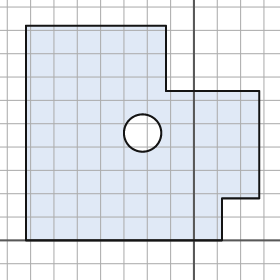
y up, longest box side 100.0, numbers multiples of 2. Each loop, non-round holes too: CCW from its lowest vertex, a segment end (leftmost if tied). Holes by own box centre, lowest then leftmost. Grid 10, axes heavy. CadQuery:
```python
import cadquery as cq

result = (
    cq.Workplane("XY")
    .moveTo(-72.0, 0.0)
    .lineTo(12.0, 0.0)
    .lineTo(12.0, 18.0)
    .lineTo(28.0, 18.0)
    .lineTo(28.0, 64.0)
    .lineTo(-12.0, 64.0)
    .lineTo(-12.0, 92.0)
    .lineTo(-72.0, 92.0)
    .close()
    .moveTo(-22.0, 46.0)
    .circle(8.0)
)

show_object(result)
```